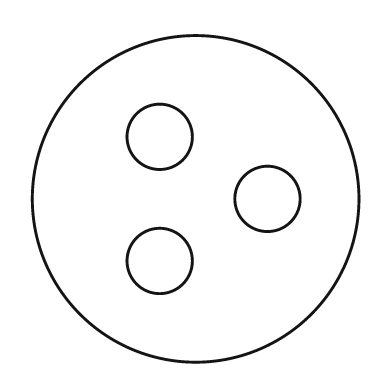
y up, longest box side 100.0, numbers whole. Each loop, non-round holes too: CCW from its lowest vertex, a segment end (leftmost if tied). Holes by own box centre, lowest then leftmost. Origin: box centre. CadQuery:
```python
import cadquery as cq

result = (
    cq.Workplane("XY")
    .moveTo(0.0, 0.0)
    .circle(50.0)
    .moveTo(-11.0, -19.0)
    .circle(10.0)
    .moveTo(22.0, 0.0)
    .circle(10.0)
    .moveTo(-11.0, 19.0)
    .circle(10.0)
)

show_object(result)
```